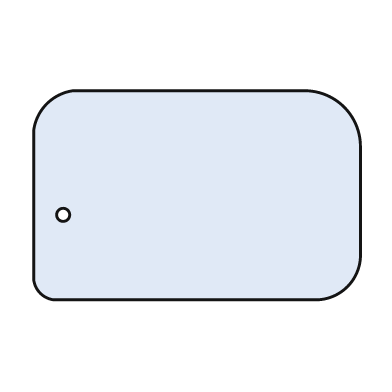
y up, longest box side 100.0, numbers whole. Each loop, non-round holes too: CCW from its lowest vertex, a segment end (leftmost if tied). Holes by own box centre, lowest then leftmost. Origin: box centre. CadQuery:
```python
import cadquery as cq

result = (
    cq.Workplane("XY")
    .moveTo(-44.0, -32.0)
    .lineTo(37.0, -32.0)
    .threePointArc((46.0, -28.0), (50.0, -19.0))
    .lineTo(50.0, 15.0)
    .threePointArc((45.0, 27.0), (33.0, 32.0))
    .lineTo(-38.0, 32.0)
    .threePointArc((-46.0, 28.0), (-50.0, 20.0))
    .lineTo(-50.0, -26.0)
    .threePointArc((-48.0, -30.0), (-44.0, -32.0))
    .close()
    .moveTo(-41.0, -6.0)
    .circle(2.0)
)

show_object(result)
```